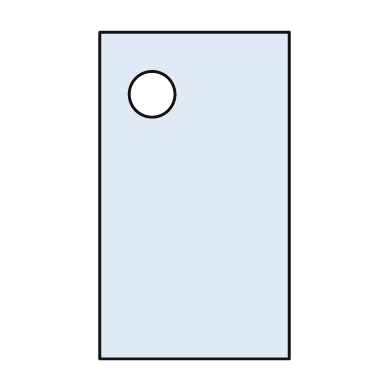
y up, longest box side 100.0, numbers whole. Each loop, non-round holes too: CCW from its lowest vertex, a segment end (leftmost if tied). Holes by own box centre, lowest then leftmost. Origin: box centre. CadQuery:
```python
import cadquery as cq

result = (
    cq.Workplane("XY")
    .moveTo(-29.0, -50.0)
    .lineTo(29.0, -50.0)
    .lineTo(29.0, 50.0)
    .lineTo(-29.0, 50.0)
    .close()
    .moveTo(-13.0, 31.0)
    .circle(7.0)
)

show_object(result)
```